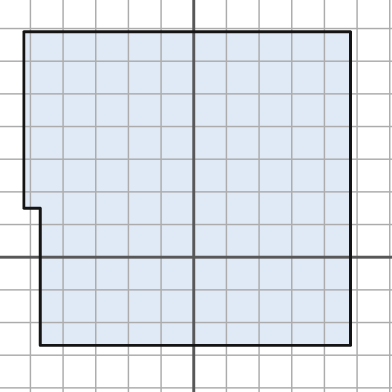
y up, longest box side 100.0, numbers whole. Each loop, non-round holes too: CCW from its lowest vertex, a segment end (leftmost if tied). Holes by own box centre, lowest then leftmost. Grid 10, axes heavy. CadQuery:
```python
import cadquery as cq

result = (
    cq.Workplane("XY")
    .moveTo(-47.0, -27.0)
    .lineTo(48.0, -27.0)
    .lineTo(48.0, 69.0)
    .lineTo(-52.0, 69.0)
    .lineTo(-52.0, 15.0)
    .lineTo(-47.0, 15.0)
    .close()
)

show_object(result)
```